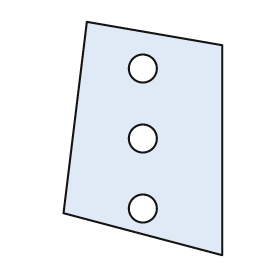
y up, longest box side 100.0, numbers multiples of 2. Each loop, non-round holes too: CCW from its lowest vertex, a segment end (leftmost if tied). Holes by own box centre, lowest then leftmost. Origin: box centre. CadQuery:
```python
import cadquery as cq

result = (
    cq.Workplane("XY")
    .moveTo(34.0, -50.0)
    .lineTo(34.0, 40.0)
    .lineTo(-24.0, 50.0)
    .lineTo(-34.0, -32.0)
    .close()
    .moveTo(0.0, -30.0)
    .circle(6.0)
    .moveTo(0.0, 0.0)
    .circle(6.0)
    .moveTo(0.0, 30.0)
    .circle(6.0)
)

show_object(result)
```